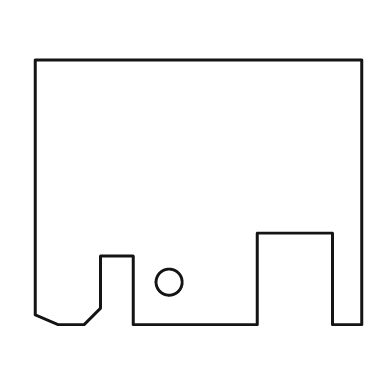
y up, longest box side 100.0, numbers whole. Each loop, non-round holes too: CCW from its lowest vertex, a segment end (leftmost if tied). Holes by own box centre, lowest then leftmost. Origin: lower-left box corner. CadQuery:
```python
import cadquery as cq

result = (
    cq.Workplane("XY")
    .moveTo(7.0, 0.0)
    .lineTo(15.0, 0.0)
    .lineTo(20.0, 5.0)
    .lineTo(20.0, 21.0)
    .lineTo(30.0, 21.0)
    .lineTo(30.0, 0.0)
    .lineTo(68.0, 0.0)
    .lineTo(68.0, 28.0)
    .lineTo(91.0, 28.0)
    .lineTo(91.0, 0.0)
    .lineTo(100.0, 0.0)
    .lineTo(100.0, 81.0)
    .lineTo(0.0, 81.0)
    .lineTo(0.0, 3.0)
    .close()
    .moveTo(41.0, 13.0)
    .circle(4.0)
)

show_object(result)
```